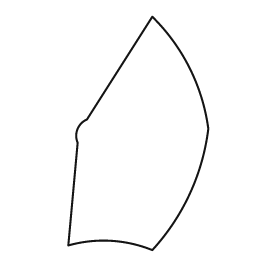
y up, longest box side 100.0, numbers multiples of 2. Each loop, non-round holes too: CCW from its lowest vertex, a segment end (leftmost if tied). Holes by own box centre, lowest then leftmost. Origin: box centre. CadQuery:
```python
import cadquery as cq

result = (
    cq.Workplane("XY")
    .moveTo(6.0, -50.0)
    .threePointArc((22.0, -26.0), (30.0, 2.0))
    .threePointArc((22.0, 28.0), (6.0, 50.0))
    .lineTo(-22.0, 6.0)
    .threePointArc((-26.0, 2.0), (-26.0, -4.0))
    .lineTo(-30.0, -48.0)
    .threePointArc((-12.0, -46.0), (6.0, -50.0))
    .close()
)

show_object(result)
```